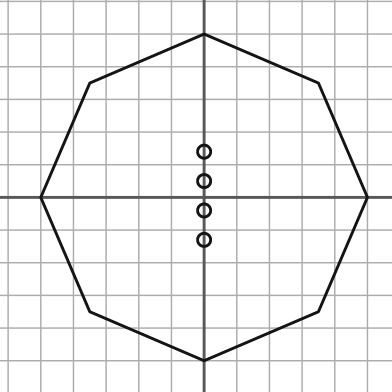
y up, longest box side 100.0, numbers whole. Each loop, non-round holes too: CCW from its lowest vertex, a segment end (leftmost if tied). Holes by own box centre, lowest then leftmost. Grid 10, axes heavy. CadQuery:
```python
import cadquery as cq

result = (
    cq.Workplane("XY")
    .moveTo(0.0, -50.0)
    .lineTo(35.0, -35.0)
    .lineTo(50.0, 0.0)
    .lineTo(35.0, 35.0)
    .lineTo(0.0, 50.0)
    .lineTo(-35.0, 35.0)
    .lineTo(-50.0, 0.0)
    .lineTo(-35.0, -35.0)
    .close()
    .moveTo(0.0, -13.0)
    .circle(2.0)
    .moveTo(0.0, -4.0)
    .circle(2.0)
    .moveTo(0.0, 5.0)
    .circle(2.0)
    .moveTo(0.0, 14.0)
    .circle(2.0)
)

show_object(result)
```